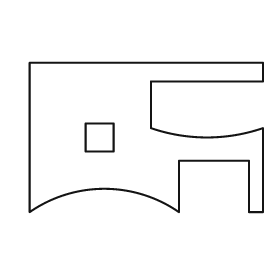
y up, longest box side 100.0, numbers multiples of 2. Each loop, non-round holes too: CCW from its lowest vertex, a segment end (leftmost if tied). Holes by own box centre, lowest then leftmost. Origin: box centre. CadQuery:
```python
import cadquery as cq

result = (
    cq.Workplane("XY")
    .moveTo(-50.0, -32.0)
    .threePointArc((-18.0, -22.0), (14.0, -32.0))
    .lineTo(14.0, -10.0)
    .lineTo(44.0, -10.0)
    .lineTo(44.0, -32.0)
    .lineTo(50.0, -32.0)
    .lineTo(50.0, 4.0)
    .threePointArc((26.0, 0.0), (2.0, 4.0))
    .lineTo(2.0, 24.0)
    .lineTo(50.0, 24.0)
    .lineTo(50.0, 32.0)
    .lineTo(-50.0, 32.0)
    .close()
    .moveTo(-26.0, -6.0)
    .lineTo(-14.0, -6.0)
    .lineTo(-14.0, 6.0)
    .lineTo(-26.0, 6.0)
    .close()
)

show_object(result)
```